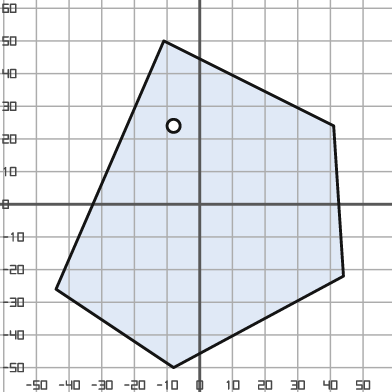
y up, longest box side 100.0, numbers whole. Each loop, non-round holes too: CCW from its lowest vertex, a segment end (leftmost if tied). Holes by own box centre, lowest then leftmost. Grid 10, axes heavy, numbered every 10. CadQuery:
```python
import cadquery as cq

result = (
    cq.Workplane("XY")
    .moveTo(-8.0, -50.0)
    .lineTo(44.0, -22.0)
    .lineTo(41.0, 24.0)
    .lineTo(-11.0, 50.0)
    .lineTo(-44.0, -26.0)
    .close()
    .moveTo(-8.0, 24.0)
    .circle(2.0)
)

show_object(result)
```